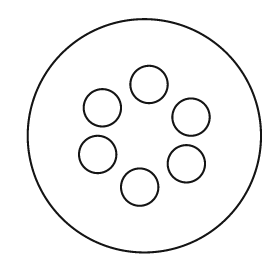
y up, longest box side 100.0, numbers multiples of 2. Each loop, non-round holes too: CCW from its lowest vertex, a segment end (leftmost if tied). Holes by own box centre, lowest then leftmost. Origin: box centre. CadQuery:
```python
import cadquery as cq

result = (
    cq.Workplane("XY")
    .moveTo(0.0, 0.0)
    .circle(50.0)
    .moveTo(-2.0, -22.0)
    .circle(8.0)
    .moveTo(18.0, -12.0)
    .circle(8.0)
    .moveTo(-20.0, -8.0)
    .circle(8.0)
    .moveTo(20.0, 8.0)
    .circle(8.0)
    .moveTo(-18.0, 12.0)
    .circle(8.0)
    .moveTo(2.0, 22.0)
    .circle(8.0)
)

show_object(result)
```